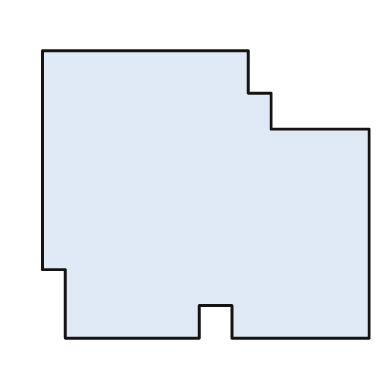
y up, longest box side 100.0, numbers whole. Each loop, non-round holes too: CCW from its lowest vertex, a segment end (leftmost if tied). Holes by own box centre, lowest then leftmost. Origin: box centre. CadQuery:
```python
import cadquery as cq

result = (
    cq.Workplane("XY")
    .moveTo(-43.0, -44.0)
    .lineTo(-2.0, -44.0)
    .lineTo(-2.0, -34.0)
    .lineTo(8.0, -34.0)
    .lineTo(8.0, -44.0)
    .lineTo(50.0, -44.0)
    .lineTo(50.0, 20.0)
    .lineTo(20.0, 20.0)
    .lineTo(20.0, 31.0)
    .lineTo(13.0, 31.0)
    .lineTo(13.0, 44.0)
    .lineTo(-50.0, 44.0)
    .lineTo(-50.0, -23.0)
    .lineTo(-43.0, -23.0)
    .close()
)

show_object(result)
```